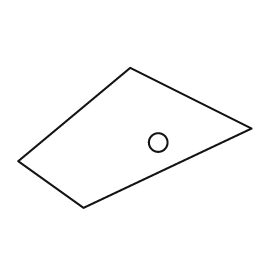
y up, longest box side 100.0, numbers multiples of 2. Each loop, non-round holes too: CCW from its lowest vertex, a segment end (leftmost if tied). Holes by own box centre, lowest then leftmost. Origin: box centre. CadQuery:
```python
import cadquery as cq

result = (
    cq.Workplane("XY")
    .moveTo(-22.0, -30.0)
    .lineTo(50.0, 4.0)
    .lineTo(-2.0, 30.0)
    .lineTo(-50.0, -10.0)
    .close()
    .moveTo(10.0, -2.0)
    .circle(4.0)
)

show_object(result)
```